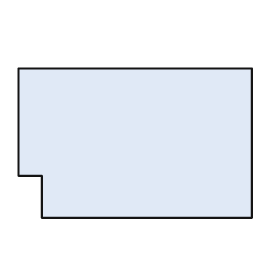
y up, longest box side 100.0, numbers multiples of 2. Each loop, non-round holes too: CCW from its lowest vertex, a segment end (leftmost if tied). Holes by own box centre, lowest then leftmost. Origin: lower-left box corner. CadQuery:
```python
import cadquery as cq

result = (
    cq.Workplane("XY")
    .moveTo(10.0, 0.0)
    .lineTo(100.0, 0.0)
    .lineTo(100.0, 64.0)
    .lineTo(0.0, 64.0)
    .lineTo(0.0, 18.0)
    .lineTo(10.0, 18.0)
    .close()
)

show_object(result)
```